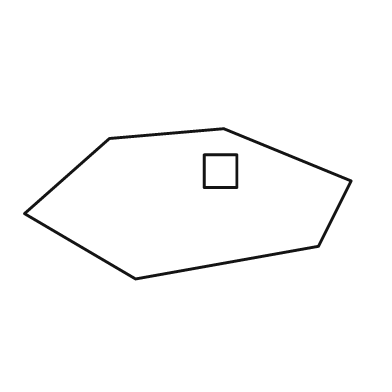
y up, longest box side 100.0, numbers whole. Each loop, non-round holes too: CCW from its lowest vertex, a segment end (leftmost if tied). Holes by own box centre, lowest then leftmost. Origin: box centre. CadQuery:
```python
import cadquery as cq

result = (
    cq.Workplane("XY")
    .moveTo(-16.0, -23.0)
    .lineTo(40.0, -13.0)
    .lineTo(50.0, 7.0)
    .lineTo(11.0, 23.0)
    .lineTo(-24.0, 20.0)
    .lineTo(-50.0, -3.0)
    .close()
    .moveTo(5.0, 5.0)
    .lineTo(15.0, 5.0)
    .lineTo(15.0, 15.0)
    .lineTo(5.0, 15.0)
    .close()
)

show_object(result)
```